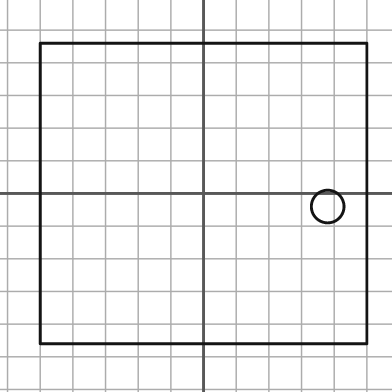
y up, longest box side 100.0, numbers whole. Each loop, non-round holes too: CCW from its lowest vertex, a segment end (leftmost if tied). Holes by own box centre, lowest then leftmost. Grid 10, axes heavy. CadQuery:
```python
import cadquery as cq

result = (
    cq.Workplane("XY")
    .moveTo(-50.0, -46.0)
    .lineTo(50.0, -46.0)
    .lineTo(50.0, 46.0)
    .lineTo(-50.0, 46.0)
    .close()
    .moveTo(38.0, -4.0)
    .circle(5.0)
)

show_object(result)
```